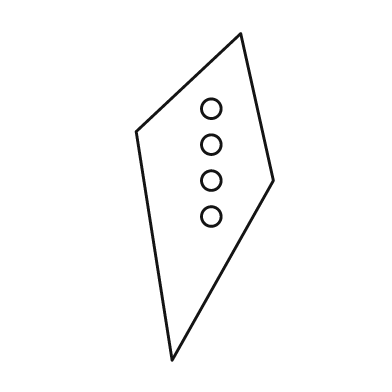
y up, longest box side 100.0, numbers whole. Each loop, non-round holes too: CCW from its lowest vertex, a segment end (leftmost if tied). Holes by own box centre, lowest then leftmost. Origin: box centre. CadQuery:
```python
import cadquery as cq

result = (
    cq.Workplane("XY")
    .moveTo(-10.0, -50.0)
    .lineTo(21.0, 5.0)
    .lineTo(11.0, 50.0)
    .lineTo(-21.0, 20.0)
    .close()
    .moveTo(2.0, -6.0)
    .circle(3.0)
    .moveTo(2.0, 5.0)
    .circle(3.0)
    .moveTo(2.0, 16.0)
    .circle(3.0)
    .moveTo(2.0, 27.0)
    .circle(3.0)
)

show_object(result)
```